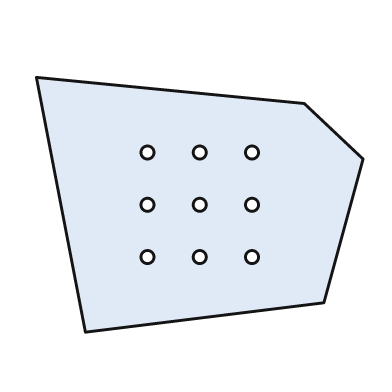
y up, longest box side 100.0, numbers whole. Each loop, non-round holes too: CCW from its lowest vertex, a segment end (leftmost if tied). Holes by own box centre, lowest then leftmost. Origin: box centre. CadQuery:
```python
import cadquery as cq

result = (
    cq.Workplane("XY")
    .moveTo(-35.0, -39.0)
    .lineTo(38.0, -30.0)
    .lineTo(50.0, 14.0)
    .lineTo(32.0, 31.0)
    .lineTo(-50.0, 39.0)
    .close()
    .moveTo(-16.0, -16.0)
    .circle(2.0)
    .moveTo(0.0, -16.0)
    .circle(2.0)
    .moveTo(16.0, -16.0)
    .circle(2.0)
    .moveTo(-16.0, 0.0)
    .circle(2.0)
    .moveTo(0.0, 0.0)
    .circle(2.0)
    .moveTo(16.0, 0.0)
    .circle(2.0)
    .moveTo(-16.0, 16.0)
    .circle(2.0)
    .moveTo(0.0, 16.0)
    .circle(2.0)
    .moveTo(16.0, 16.0)
    .circle(2.0)
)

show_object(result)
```